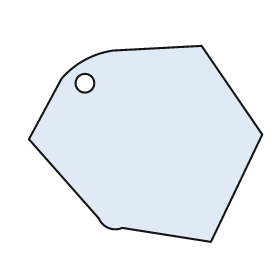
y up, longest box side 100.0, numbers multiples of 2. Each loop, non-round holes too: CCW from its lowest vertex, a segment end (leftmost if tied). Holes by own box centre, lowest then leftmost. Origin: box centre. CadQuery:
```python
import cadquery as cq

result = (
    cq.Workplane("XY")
    .moveTo(28.0, -42.0)
    .lineTo(50.0, 4.0)
    .lineTo(24.0, 42.0)
    .lineTo(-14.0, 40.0)
    .threePointArc((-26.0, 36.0), (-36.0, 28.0))
    .lineTo(-50.0, 2.0)
    .lineTo(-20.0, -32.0)
    .threePointArc((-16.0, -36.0), (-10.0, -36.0))
    .close()
    .moveTo(-26.0, 26.0)
    .circle(4.0)
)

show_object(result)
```